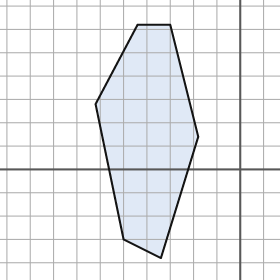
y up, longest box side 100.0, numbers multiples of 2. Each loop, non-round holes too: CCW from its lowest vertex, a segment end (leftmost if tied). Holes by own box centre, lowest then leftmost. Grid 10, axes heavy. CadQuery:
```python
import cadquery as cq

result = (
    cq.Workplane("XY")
    .moveTo(-34.0, -38.0)
    .lineTo(-18.0, 14.0)
    .lineTo(-30.0, 62.0)
    .lineTo(-44.0, 62.0)
    .lineTo(-62.0, 28.0)
    .lineTo(-50.0, -30.0)
    .close()
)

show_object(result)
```